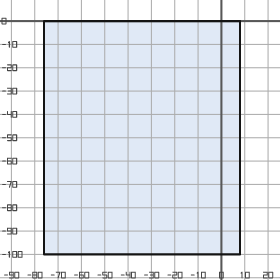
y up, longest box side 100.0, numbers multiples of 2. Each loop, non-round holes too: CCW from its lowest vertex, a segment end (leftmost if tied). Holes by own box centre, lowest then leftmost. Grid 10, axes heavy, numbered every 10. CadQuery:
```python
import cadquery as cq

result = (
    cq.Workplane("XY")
    .moveTo(-76.0, -100.0)
    .lineTo(8.0, -100.0)
    .lineTo(8.0, 0.0)
    .lineTo(-76.0, 0.0)
    .close()
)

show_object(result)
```